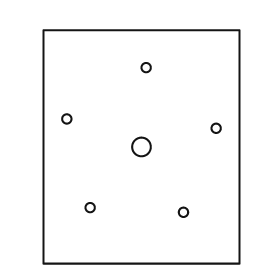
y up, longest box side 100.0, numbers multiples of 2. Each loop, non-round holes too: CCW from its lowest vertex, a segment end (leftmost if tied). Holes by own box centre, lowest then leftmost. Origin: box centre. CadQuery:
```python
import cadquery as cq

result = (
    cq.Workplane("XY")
    .moveTo(-42.0, -50.0)
    .lineTo(42.0, -50.0)
    .lineTo(42.0, 50.0)
    .lineTo(-42.0, 50.0)
    .close()
    .moveTo(18.0, -28.0)
    .circle(2.0)
    .moveTo(-22.0, -26.0)
    .circle(2.0)
    .moveTo(0.0, 0.0)
    .circle(4.0)
    .moveTo(32.0, 8.0)
    .circle(2.0)
    .moveTo(-32.0, 12.0)
    .circle(2.0)
    .moveTo(2.0, 34.0)
    .circle(2.0)
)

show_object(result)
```